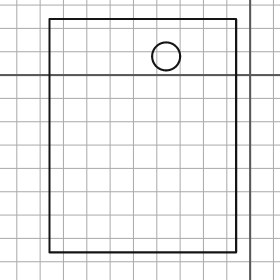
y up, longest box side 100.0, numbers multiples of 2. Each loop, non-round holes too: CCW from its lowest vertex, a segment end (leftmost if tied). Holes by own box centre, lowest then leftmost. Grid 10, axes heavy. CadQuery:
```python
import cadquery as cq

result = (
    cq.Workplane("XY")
    .moveTo(-86.0, -76.0)
    .lineTo(-6.0, -76.0)
    .lineTo(-6.0, 24.0)
    .lineTo(-86.0, 24.0)
    .close()
    .moveTo(-36.0, 8.0)
    .circle(6.0)
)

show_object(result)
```